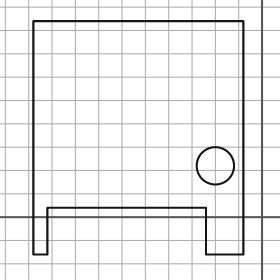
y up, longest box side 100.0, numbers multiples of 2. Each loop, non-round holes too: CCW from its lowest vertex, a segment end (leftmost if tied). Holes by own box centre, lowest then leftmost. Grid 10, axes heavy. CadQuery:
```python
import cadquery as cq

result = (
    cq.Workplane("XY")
    .moveTo(-98.0, -16.0)
    .lineTo(-92.0, -16.0)
    .lineTo(-92.0, 4.0)
    .lineTo(-24.0, 4.0)
    .lineTo(-24.0, -16.0)
    .lineTo(-8.0, -16.0)
    .lineTo(-8.0, 84.0)
    .lineTo(-98.0, 84.0)
    .close()
    .moveTo(-20.0, 22.0)
    .circle(8.0)
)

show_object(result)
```